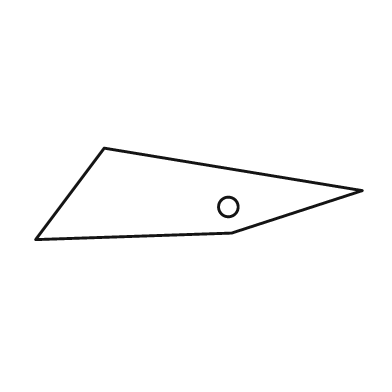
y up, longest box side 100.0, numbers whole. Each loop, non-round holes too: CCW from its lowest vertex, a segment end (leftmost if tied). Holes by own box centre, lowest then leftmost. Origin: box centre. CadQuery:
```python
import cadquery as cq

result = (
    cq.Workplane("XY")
    .moveTo(-50.0, -14.0)
    .lineTo(10.0, -12.0)
    .lineTo(50.0, 1.0)
    .lineTo(-29.0, 14.0)
    .close()
    .moveTo(9.0, -4.0)
    .circle(3.0)
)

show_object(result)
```